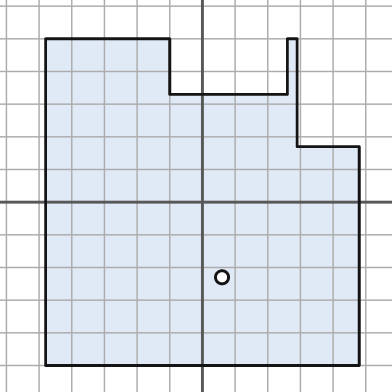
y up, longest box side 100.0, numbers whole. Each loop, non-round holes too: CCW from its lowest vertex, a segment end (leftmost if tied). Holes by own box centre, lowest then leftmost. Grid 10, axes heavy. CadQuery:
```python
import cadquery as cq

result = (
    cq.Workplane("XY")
    .moveTo(-48.0, -50.0)
    .lineTo(48.0, -50.0)
    .lineTo(48.0, 17.0)
    .lineTo(29.0, 17.0)
    .lineTo(29.0, 50.0)
    .lineTo(26.0, 50.0)
    .lineTo(26.0, 33.0)
    .lineTo(-10.0, 33.0)
    .lineTo(-10.0, 50.0)
    .lineTo(-48.0, 50.0)
    .close()
    .moveTo(6.0, -23.0)
    .circle(2.0)
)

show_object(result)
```